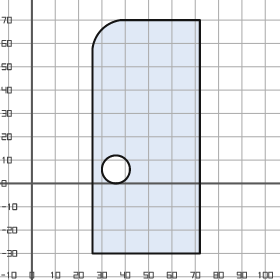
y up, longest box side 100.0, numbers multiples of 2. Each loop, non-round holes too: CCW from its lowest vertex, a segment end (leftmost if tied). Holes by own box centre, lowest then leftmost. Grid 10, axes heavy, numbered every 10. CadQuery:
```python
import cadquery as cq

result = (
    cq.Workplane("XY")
    .moveTo(26.0, -30.0)
    .lineTo(72.0, -30.0)
    .lineTo(72.0, 70.0)
    .lineTo(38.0, 70.0)
    .threePointArc((30.0, 66.0), (26.0, 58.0))
    .close()
    .moveTo(36.0, 6.0)
    .circle(6.0)
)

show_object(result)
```